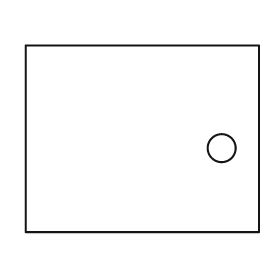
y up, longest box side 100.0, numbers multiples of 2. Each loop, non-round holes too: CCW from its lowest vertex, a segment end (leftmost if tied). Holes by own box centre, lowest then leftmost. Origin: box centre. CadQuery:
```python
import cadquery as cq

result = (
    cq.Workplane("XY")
    .moveTo(-50.0, -40.0)
    .lineTo(50.0, -40.0)
    .lineTo(50.0, 40.0)
    .lineTo(-50.0, 40.0)
    .close()
    .moveTo(34.0, -4.0)
    .circle(6.0)
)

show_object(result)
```